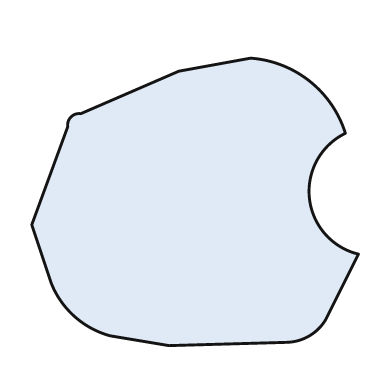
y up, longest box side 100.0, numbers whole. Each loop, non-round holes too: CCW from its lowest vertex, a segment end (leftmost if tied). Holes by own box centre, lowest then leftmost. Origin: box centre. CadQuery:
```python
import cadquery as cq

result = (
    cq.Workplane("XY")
    .moveTo(-8.0, -44.0)
    .lineTo(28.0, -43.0)
    .threePointArc((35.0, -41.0), (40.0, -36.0))
    .lineTo(50.0, -16.0)
    .threePointArc((35.0, 1.0), (46.0, 21.0))
    .threePointArc((35.0, 37.0), (17.0, 44.0))
    .lineTo(-5.0, 40.0)
    .lineTo(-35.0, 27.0)
    .threePointArc((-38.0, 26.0), (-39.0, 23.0))
    .lineTo(-50.0, -7.0)
    .lineTo(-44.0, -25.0)
    .threePointArc((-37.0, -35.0), (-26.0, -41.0))
    .close()
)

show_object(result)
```